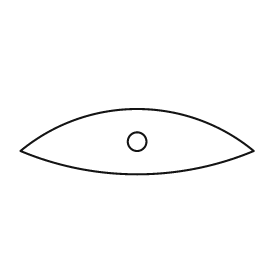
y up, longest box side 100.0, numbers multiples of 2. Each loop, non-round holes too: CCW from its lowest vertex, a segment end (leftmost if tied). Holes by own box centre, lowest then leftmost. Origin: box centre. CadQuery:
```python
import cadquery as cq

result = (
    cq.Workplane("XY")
    .moveTo(-50.0, -4.0)
    .threePointArc((0.0, -14.0), (50.0, -4.0))
    .threePointArc((0.0, 14.0), (-50.0, -4.0))
    .close()
    .moveTo(0.0, 0.0)
    .circle(4.0)
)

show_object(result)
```